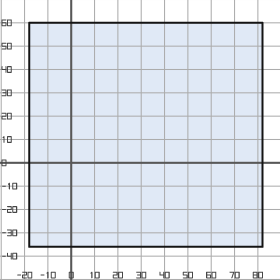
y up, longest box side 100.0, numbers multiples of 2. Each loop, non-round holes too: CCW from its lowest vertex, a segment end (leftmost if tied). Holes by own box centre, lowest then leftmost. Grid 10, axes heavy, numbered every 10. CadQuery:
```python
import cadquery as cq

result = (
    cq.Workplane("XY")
    .moveTo(-18.0, -36.0)
    .lineTo(82.0, -36.0)
    .lineTo(82.0, 60.0)
    .lineTo(-18.0, 60.0)
    .close()
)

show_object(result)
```